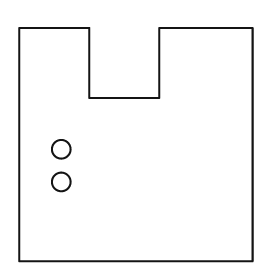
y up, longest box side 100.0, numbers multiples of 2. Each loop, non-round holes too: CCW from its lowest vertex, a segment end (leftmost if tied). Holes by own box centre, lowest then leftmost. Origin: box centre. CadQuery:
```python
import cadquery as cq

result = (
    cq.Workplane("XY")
    .moveTo(-50.0, -50.0)
    .lineTo(50.0, -50.0)
    .lineTo(50.0, 50.0)
    .lineTo(10.0, 50.0)
    .lineTo(10.0, 20.0)
    .lineTo(-20.0, 20.0)
    .lineTo(-20.0, 50.0)
    .lineTo(-50.0, 50.0)
    .close()
    .moveTo(-32.0, -16.0)
    .circle(4.0)
    .moveTo(-32.0, -2.0)
    .circle(4.0)
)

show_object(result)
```